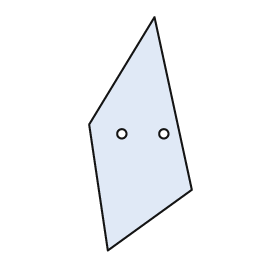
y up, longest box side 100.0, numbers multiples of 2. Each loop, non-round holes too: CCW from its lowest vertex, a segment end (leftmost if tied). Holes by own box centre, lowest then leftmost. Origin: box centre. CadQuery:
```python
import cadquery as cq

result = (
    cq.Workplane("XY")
    .moveTo(-14.0, -50.0)
    .lineTo(22.0, -24.0)
    .lineTo(6.0, 50.0)
    .lineTo(-22.0, 4.0)
    .close()
    .moveTo(-8.0, 0.0)
    .circle(2.0)
    .moveTo(10.0, 0.0)
    .circle(2.0)
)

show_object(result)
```